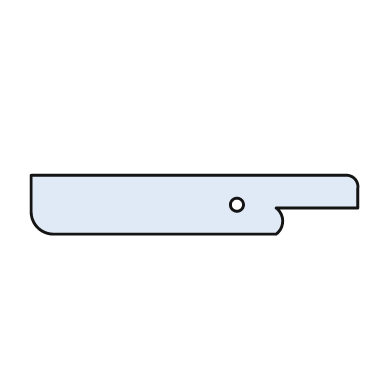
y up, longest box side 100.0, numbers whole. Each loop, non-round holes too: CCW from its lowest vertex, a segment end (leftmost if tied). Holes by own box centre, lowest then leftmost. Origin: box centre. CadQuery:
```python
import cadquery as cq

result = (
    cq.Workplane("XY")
    .moveTo(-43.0, -9.0)
    .lineTo(25.0, -9.0)
    .threePointArc((27.0, -5.0), (25.0, -1.0))
    .lineTo(50.0, -1.0)
    .lineTo(50.0, 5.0)
    .threePointArc((49.0, 8.0), (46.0, 9.0))
    .lineTo(-50.0, 9.0)
    .lineTo(-50.0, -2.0)
    .threePointArc((-48.0, -7.0), (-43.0, -9.0))
    .close()
    .moveTo(13.0, 0.0)
    .circle(2.0)
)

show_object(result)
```